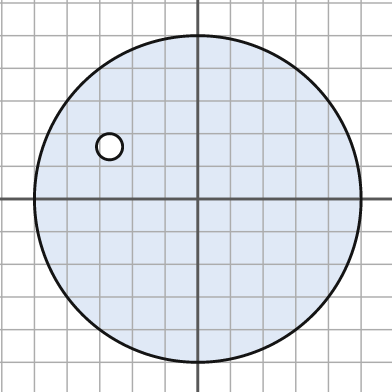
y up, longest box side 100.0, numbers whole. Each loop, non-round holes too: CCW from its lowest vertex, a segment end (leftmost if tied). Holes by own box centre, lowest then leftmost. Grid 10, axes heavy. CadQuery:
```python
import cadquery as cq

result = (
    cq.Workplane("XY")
    .moveTo(0.0, 0.0)
    .circle(50.0)
    .moveTo(-27.0, 16.0)
    .circle(4.0)
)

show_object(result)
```